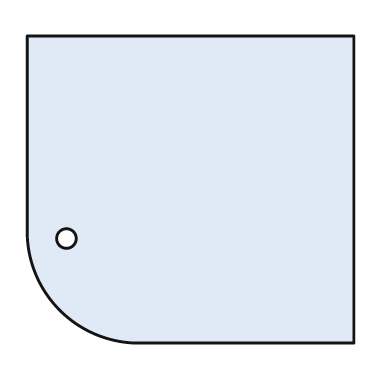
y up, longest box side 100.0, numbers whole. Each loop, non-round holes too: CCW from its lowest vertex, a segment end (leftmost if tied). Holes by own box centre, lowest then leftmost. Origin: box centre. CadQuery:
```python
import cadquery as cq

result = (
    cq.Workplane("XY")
    .moveTo(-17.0, -47.0)
    .lineTo(50.0, -47.0)
    .lineTo(50.0, 47.0)
    .lineTo(-50.0, 47.0)
    .lineTo(-50.0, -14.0)
    .threePointArc((-40.0, -37.0), (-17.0, -47.0))
    .close()
    .moveTo(-38.0, -15.0)
    .circle(3.0)
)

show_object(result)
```